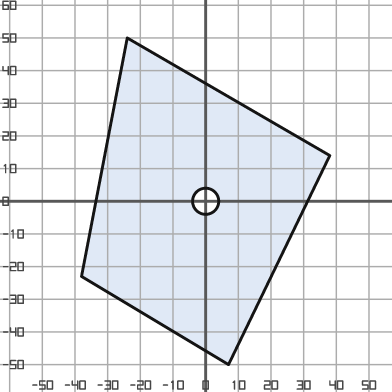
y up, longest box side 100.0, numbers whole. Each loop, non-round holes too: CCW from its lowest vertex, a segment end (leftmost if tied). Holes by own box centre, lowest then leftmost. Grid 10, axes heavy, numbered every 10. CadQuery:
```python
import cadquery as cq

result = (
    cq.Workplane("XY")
    .moveTo(7.0, -50.0)
    .lineTo(38.0, 14.0)
    .lineTo(-24.0, 50.0)
    .lineTo(-38.0, -23.0)
    .close()
    .moveTo(0.0, 0.0)
    .circle(4.0)
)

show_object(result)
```